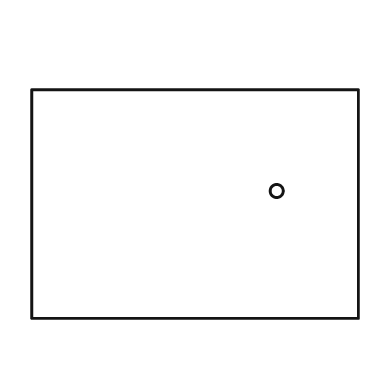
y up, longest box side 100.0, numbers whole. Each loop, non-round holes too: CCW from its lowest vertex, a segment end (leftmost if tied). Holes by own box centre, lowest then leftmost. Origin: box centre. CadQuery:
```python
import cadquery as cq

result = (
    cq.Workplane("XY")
    .moveTo(-50.0, -35.0)
    .lineTo(50.0, -35.0)
    .lineTo(50.0, 35.0)
    .lineTo(-50.0, 35.0)
    .close()
    .moveTo(25.0, 4.0)
    .circle(2.0)
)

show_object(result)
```